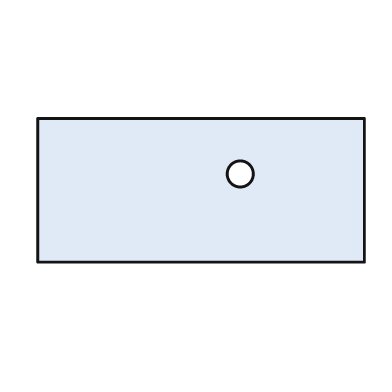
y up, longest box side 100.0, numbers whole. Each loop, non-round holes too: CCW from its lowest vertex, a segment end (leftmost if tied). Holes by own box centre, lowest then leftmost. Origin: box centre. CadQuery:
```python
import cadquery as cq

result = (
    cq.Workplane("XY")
    .moveTo(-50.0, -22.0)
    .lineTo(50.0, -22.0)
    .lineTo(50.0, 22.0)
    .lineTo(-50.0, 22.0)
    .close()
    .moveTo(12.0, 5.0)
    .circle(4.0)
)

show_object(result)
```